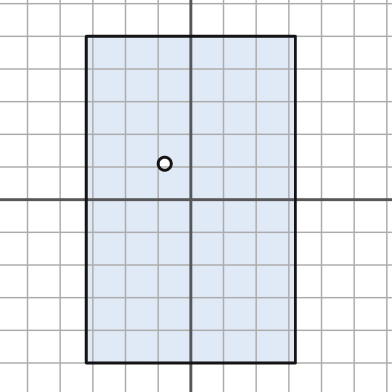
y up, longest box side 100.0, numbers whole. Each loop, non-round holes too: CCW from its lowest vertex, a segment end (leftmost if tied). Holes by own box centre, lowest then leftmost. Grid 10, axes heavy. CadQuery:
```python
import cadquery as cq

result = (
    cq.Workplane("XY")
    .moveTo(-32.0, -50.0)
    .lineTo(32.0, -50.0)
    .lineTo(32.0, 50.0)
    .lineTo(-32.0, 50.0)
    .close()
    .moveTo(-8.0, 11.0)
    .circle(2.0)
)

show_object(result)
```